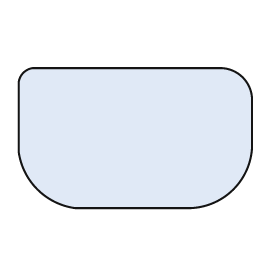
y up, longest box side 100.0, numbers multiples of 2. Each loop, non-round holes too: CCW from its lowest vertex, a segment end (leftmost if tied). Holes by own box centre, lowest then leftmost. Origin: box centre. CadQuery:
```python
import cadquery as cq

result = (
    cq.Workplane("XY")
    .moveTo(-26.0, -30.0)
    .lineTo(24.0, -30.0)
    .threePointArc((42.0, -22.0), (50.0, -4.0))
    .lineTo(50.0, 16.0)
    .threePointArc((46.0, 26.0), (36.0, 30.0))
    .lineTo(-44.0, 30.0)
    .threePointArc((-48.0, 28.0), (-50.0, 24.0))
    .lineTo(-50.0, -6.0)
    .threePointArc((-42.0, -22.0), (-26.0, -30.0))
    .close()
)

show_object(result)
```